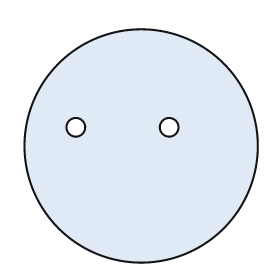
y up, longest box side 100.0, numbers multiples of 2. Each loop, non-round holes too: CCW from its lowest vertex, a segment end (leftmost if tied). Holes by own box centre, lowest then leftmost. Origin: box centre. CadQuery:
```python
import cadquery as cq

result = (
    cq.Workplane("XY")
    .moveTo(0.0, 0.0)
    .circle(50.0)
    .moveTo(-28.0, 8.0)
    .circle(4.0)
    .moveTo(12.0, 8.0)
    .circle(4.0)
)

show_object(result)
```